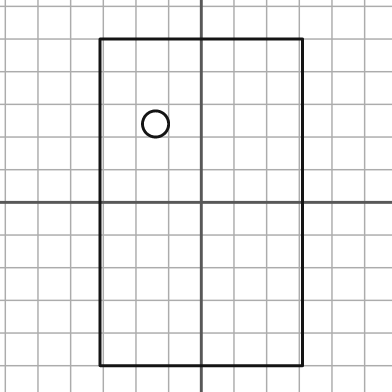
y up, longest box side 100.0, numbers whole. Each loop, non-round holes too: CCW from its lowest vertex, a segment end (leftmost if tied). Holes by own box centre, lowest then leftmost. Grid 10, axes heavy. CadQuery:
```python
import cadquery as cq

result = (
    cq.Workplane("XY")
    .moveTo(-31.0, -50.0)
    .lineTo(31.0, -50.0)
    .lineTo(31.0, 50.0)
    .lineTo(-31.0, 50.0)
    .close()
    .moveTo(-14.0, 24.0)
    .circle(4.0)
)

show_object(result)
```